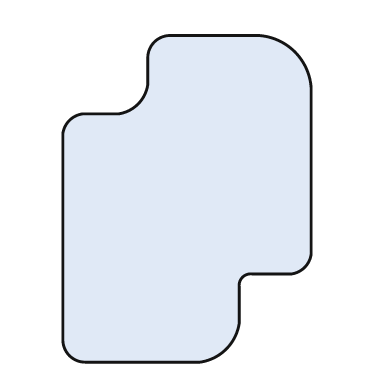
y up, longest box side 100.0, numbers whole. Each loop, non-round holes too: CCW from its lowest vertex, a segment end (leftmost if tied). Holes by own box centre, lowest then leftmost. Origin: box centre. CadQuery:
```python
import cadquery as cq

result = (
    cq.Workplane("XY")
    .moveTo(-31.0, -50.0)
    .lineTo(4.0, -50.0)
    .threePointArc((12.0, -46.0), (16.0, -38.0))
    .lineTo(16.0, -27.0)
    .threePointArc((17.0, -24.0), (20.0, -23.0))
    .lineTo(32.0, -23.0)
    .threePointArc((36.0, -21.0), (38.0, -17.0))
    .lineTo(38.0, 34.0)
    .threePointArc((33.0, 45.0), (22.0, 50.0))
    .lineTo(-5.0, 50.0)
    .threePointArc((-10.0, 48.0), (-12.0, 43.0))
    .lineTo(-12.0, 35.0)
    .threePointArc((-15.0, 29.0), (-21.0, 26.0))
    .lineTo(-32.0, 26.0)
    .threePointArc((-36.0, 24.0), (-38.0, 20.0))
    .lineTo(-38.0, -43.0)
    .threePointArc((-36.0, -48.0), (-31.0, -50.0))
    .close()
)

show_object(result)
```